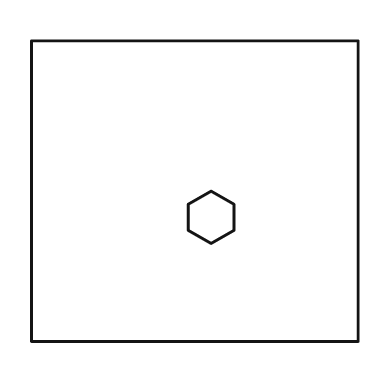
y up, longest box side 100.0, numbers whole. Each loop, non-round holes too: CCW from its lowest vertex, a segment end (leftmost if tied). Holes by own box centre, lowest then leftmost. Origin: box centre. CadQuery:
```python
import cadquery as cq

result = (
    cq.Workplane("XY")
    .moveTo(-50.0, -46.0)
    .lineTo(50.0, -46.0)
    .lineTo(50.0, 46.0)
    .lineTo(-50.0, 46.0)
    .close()
    .moveTo(5.0, -16.0)
    .lineTo(12.0, -12.0)
    .lineTo(12.0, -4.0)
    .lineTo(5.0, 0.0)
    .lineTo(-2.0, -4.0)
    .lineTo(-2.0, -12.0)
    .close()
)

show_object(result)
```